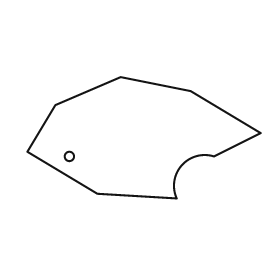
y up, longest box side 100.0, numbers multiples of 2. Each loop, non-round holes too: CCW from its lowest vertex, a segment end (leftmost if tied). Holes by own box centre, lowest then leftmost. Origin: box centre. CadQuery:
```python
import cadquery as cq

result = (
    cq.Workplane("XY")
    .moveTo(14.0, -26.0)
    .threePointArc((16.0, -12.0), (30.0, -8.0))
    .lineTo(50.0, 2.0)
    .lineTo(20.0, 20.0)
    .lineTo(-10.0, 26.0)
    .lineTo(-38.0, 14.0)
    .lineTo(-50.0, -6.0)
    .lineTo(-20.0, -24.0)
    .close()
    .moveTo(-32.0, -8.0)
    .circle(2.0)
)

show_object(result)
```